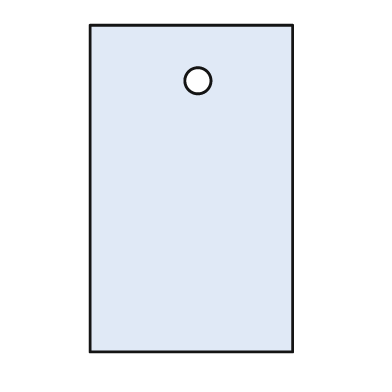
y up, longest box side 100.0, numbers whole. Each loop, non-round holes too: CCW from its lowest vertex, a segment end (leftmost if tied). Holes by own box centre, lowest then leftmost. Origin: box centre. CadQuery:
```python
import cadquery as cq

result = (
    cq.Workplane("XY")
    .moveTo(-31.0, -50.0)
    .lineTo(31.0, -50.0)
    .lineTo(31.0, 50.0)
    .lineTo(-31.0, 50.0)
    .close()
    .moveTo(2.0, 33.0)
    .circle(4.0)
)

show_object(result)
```